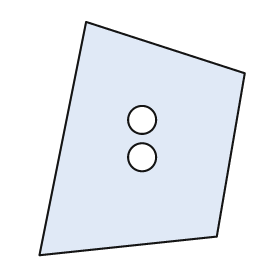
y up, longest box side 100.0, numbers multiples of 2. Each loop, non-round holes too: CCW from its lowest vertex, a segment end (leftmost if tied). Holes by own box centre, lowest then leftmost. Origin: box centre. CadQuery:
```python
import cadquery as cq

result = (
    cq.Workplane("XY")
    .moveTo(-44.0, -50.0)
    .lineTo(32.0, -42.0)
    .lineTo(44.0, 28.0)
    .lineTo(-24.0, 50.0)
    .close()
    .moveTo(0.0, -8.0)
    .circle(6.0)
    .moveTo(0.0, 8.0)
    .circle(6.0)
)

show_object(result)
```